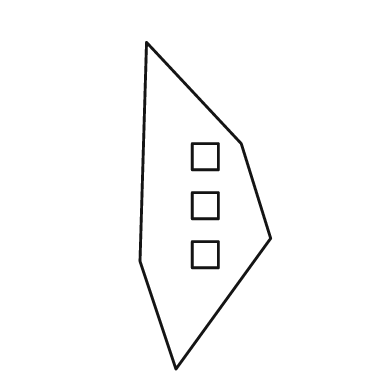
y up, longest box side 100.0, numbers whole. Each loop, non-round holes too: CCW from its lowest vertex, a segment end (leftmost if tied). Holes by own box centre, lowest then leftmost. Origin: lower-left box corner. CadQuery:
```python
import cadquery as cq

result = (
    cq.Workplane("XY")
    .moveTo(11.0, 0.0)
    .lineTo(40.0, 40.0)
    .lineTo(31.0, 69.0)
    .lineTo(2.0, 100.0)
    .lineTo(0.0, 33.0)
    .close()
    .moveTo(16.0, 31.0)
    .lineTo(24.0, 31.0)
    .lineTo(24.0, 39.0)
    .lineTo(16.0, 39.0)
    .close()
    .moveTo(16.0, 46.0)
    .lineTo(24.0, 46.0)
    .lineTo(24.0, 54.0)
    .lineTo(16.0, 54.0)
    .close()
    .moveTo(16.0, 61.0)
    .lineTo(24.0, 61.0)
    .lineTo(24.0, 69.0)
    .lineTo(16.0, 69.0)
    .close()
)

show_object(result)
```